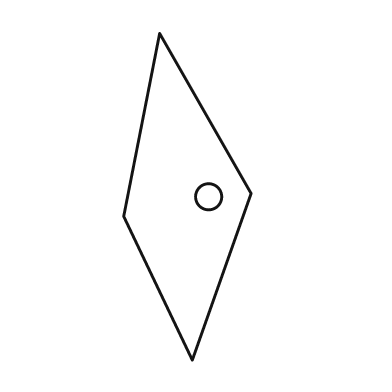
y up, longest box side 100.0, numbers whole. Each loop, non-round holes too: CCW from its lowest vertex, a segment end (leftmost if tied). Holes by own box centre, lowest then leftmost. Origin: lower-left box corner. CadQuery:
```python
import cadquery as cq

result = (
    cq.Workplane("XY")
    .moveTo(21.0, 0.0)
    .lineTo(39.0, 51.0)
    .lineTo(11.0, 100.0)
    .lineTo(0.0, 44.0)
    .close()
    .moveTo(26.0, 50.0)
    .circle(4.0)
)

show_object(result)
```